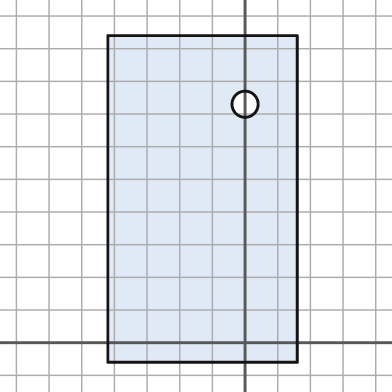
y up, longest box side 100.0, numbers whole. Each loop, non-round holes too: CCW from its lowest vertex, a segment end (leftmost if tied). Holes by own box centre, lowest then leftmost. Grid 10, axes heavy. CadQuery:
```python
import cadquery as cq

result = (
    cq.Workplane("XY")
    .moveTo(-42.0, -6.0)
    .lineTo(16.0, -6.0)
    .lineTo(16.0, 94.0)
    .lineTo(-42.0, 94.0)
    .close()
    .moveTo(0.0, 73.0)
    .circle(4.0)
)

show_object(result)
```